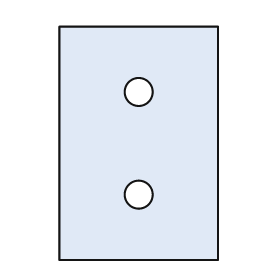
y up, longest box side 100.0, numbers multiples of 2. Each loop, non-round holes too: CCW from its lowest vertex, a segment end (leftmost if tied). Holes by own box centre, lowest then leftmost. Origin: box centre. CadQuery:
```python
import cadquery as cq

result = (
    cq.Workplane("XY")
    .moveTo(-34.0, -50.0)
    .lineTo(34.0, -50.0)
    .lineTo(34.0, 50.0)
    .lineTo(-34.0, 50.0)
    .close()
    .moveTo(0.0, -22.0)
    .circle(6.0)
    .moveTo(0.0, 22.0)
    .circle(6.0)
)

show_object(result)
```